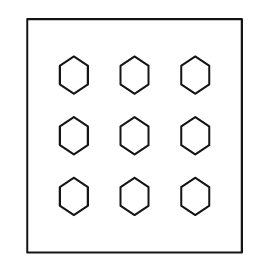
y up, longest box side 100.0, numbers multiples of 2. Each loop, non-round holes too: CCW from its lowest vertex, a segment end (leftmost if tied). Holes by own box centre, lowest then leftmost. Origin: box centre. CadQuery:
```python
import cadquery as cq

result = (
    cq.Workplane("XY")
    .moveTo(-46.0, -50.0)
    .lineTo(46.0, -50.0)
    .lineTo(46.0, 50.0)
    .lineTo(-46.0, 50.0)
    .close()
    .moveTo(-26.0, -34.0)
    .lineTo(-20.0, -30.0)
    .lineTo(-20.0, -22.0)
    .lineTo(-26.0, -18.0)
    .lineTo(-32.0, -22.0)
    .lineTo(-32.0, -30.0)
    .close()
    .moveTo(0.0, -34.0)
    .lineTo(6.0, -30.0)
    .lineTo(6.0, -22.0)
    .lineTo(0.0, -18.0)
    .lineTo(-6.0, -22.0)
    .lineTo(-6.0, -30.0)
    .close()
    .moveTo(26.0, -34.0)
    .lineTo(32.0, -30.0)
    .lineTo(32.0, -22.0)
    .lineTo(26.0, -18.0)
    .lineTo(20.0, -22.0)
    .lineTo(20.0, -30.0)
    .close()
    .moveTo(-26.0, -8.0)
    .lineTo(-20.0, -4.0)
    .lineTo(-20.0, 4.0)
    .lineTo(-26.0, 8.0)
    .lineTo(-32.0, 4.0)
    .lineTo(-32.0, -4.0)
    .close()
    .moveTo(0.0, -8.0)
    .lineTo(6.0, -4.0)
    .lineTo(6.0, 4.0)
    .lineTo(0.0, 8.0)
    .lineTo(-6.0, 4.0)
    .lineTo(-6.0, -4.0)
    .close()
    .moveTo(26.0, -8.0)
    .lineTo(32.0, -4.0)
    .lineTo(32.0, 4.0)
    .lineTo(26.0, 8.0)
    .lineTo(20.0, 4.0)
    .lineTo(20.0, -4.0)
    .close()
    .moveTo(-26.0, 18.0)
    .lineTo(-20.0, 22.0)
    .lineTo(-20.0, 30.0)
    .lineTo(-26.0, 34.0)
    .lineTo(-32.0, 30.0)
    .lineTo(-32.0, 22.0)
    .close()
    .moveTo(0.0, 18.0)
    .lineTo(6.0, 22.0)
    .lineTo(6.0, 30.0)
    .lineTo(0.0, 34.0)
    .lineTo(-6.0, 30.0)
    .lineTo(-6.0, 22.0)
    .close()
    .moveTo(26.0, 18.0)
    .lineTo(32.0, 22.0)
    .lineTo(32.0, 30.0)
    .lineTo(26.0, 34.0)
    .lineTo(20.0, 30.0)
    .lineTo(20.0, 22.0)
    .close()
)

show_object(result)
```